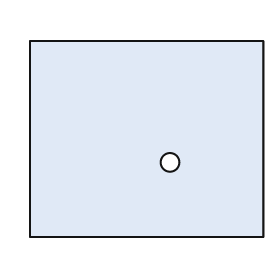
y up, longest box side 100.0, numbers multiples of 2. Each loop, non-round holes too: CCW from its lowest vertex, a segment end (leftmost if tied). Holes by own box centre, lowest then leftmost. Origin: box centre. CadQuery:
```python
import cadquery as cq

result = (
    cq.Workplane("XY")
    .moveTo(-50.0, -42.0)
    .lineTo(50.0, -42.0)
    .lineTo(50.0, 42.0)
    .lineTo(-50.0, 42.0)
    .close()
    .moveTo(10.0, -10.0)
    .circle(4.0)
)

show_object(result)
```